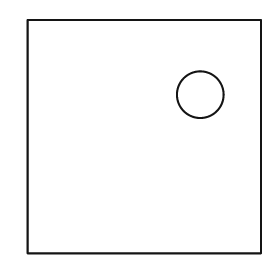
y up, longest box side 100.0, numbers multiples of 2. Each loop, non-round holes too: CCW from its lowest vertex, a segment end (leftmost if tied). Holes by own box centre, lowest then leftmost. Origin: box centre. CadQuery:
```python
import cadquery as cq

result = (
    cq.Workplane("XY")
    .moveTo(-50.0, -50.0)
    .lineTo(50.0, -50.0)
    .lineTo(50.0, 50.0)
    .lineTo(-50.0, 50.0)
    .close()
    .moveTo(24.0, 18.0)
    .circle(10.0)
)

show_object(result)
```